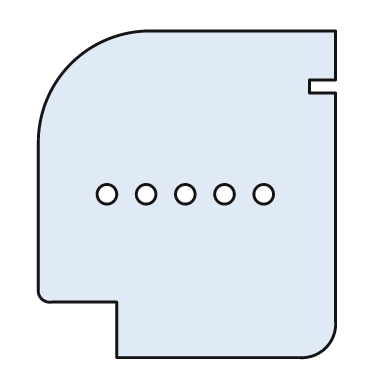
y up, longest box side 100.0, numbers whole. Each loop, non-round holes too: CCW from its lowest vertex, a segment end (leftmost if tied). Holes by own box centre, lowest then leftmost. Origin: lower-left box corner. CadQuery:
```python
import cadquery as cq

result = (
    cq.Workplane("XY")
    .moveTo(24.0, 0.0)
    .lineTo(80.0, 0.0)
    .threePointArc((88.0, 3.0), (91.0, 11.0))
    .lineTo(91.0, 81.0)
    .lineTo(83.0, 81.0)
    .lineTo(83.0, 85.0)
    .lineTo(91.0, 85.0)
    .lineTo(91.0, 100.0)
    .lineTo(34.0, 100.0)
    .threePointArc((10.0, 90.0), (0.0, 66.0))
    .lineTo(0.0, 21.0)
    .threePointArc((1.0, 18.0), (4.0, 17.0))
    .lineTo(24.0, 17.0)
    .close()
    .moveTo(21.0, 50.0)
    .circle(3.0)
    .moveTo(33.0, 50.0)
    .circle(3.0)
    .moveTo(45.0, 50.0)
    .circle(3.0)
    .moveTo(57.0, 50.0)
    .circle(3.0)
    .moveTo(69.0, 50.0)
    .circle(3.0)
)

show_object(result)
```